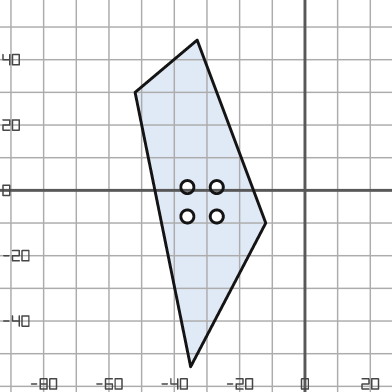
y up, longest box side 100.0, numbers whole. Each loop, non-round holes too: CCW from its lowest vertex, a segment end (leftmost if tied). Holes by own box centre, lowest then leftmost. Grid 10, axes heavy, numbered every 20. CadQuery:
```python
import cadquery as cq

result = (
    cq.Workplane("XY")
    .moveTo(-35.0, -54.0)
    .lineTo(-12.0, -10.0)
    .lineTo(-33.0, 46.0)
    .lineTo(-52.0, 30.0)
    .close()
    .moveTo(-36.0, -8.0)
    .circle(2.0)
    .moveTo(-27.0, -8.0)
    .circle(2.0)
    .moveTo(-36.0, 1.0)
    .circle(2.0)
    .moveTo(-27.0, 1.0)
    .circle(2.0)
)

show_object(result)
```